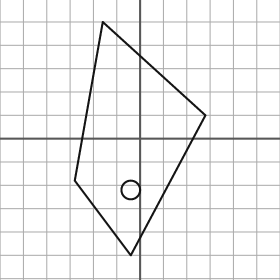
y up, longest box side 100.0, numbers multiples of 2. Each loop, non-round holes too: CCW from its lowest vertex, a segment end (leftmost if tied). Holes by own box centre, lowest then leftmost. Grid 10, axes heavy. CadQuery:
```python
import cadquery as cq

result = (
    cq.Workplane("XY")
    .moveTo(-4.0, -50.0)
    .lineTo(28.0, 10.0)
    .lineTo(-16.0, 50.0)
    .lineTo(-28.0, -18.0)
    .close()
    .moveTo(-4.0, -22.0)
    .circle(4.0)
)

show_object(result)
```